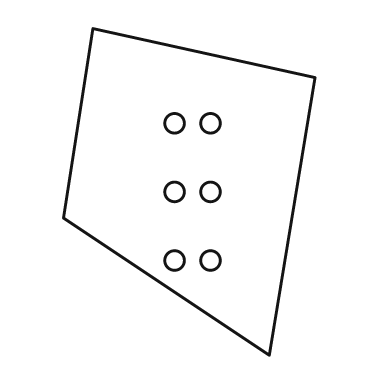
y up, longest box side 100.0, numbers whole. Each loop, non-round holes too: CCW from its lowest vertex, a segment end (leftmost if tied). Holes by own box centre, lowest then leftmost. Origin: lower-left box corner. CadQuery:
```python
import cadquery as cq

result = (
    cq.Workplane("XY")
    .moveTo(63.0, 0.0)
    .lineTo(77.0, 85.0)
    .lineTo(9.0, 100.0)
    .lineTo(0.0, 42.0)
    .close()
    .moveTo(34.0, 29.0)
    .circle(3.0)
    .moveTo(45.0, 29.0)
    .circle(3.0)
    .moveTo(34.0, 50.0)
    .circle(3.0)
    .moveTo(45.0, 50.0)
    .circle(3.0)
    .moveTo(34.0, 71.0)
    .circle(3.0)
    .moveTo(45.0, 71.0)
    .circle(3.0)
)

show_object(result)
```